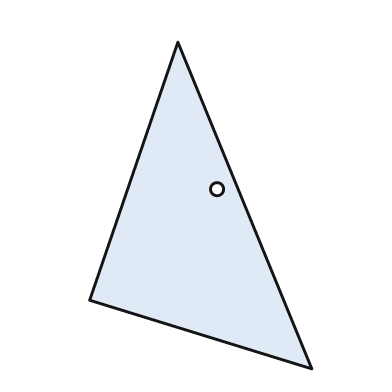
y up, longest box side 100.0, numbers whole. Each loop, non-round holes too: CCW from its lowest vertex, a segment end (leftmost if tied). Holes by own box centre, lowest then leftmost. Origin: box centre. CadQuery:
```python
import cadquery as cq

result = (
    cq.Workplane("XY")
    .moveTo(34.0, -50.0)
    .lineTo(-7.0, 50.0)
    .lineTo(-34.0, -29.0)
    .close()
    .moveTo(5.0, 5.0)
    .circle(2.0)
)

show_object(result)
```